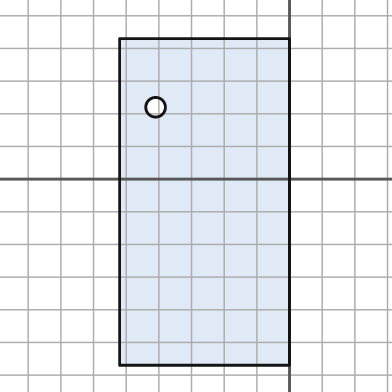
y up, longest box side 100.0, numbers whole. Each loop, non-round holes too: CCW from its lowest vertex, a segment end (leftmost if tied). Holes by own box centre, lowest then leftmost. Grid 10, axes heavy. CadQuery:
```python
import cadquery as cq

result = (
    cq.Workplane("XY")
    .moveTo(-52.0, -57.0)
    .lineTo(0.0, -57.0)
    .lineTo(0.0, 43.0)
    .lineTo(-52.0, 43.0)
    .close()
    .moveTo(-41.0, 22.0)
    .circle(3.0)
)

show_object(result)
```